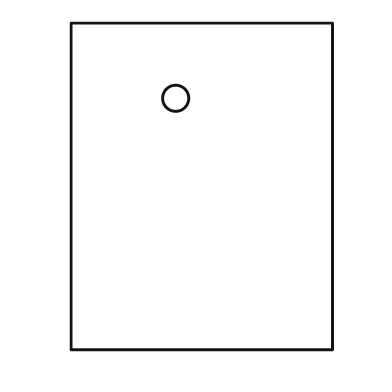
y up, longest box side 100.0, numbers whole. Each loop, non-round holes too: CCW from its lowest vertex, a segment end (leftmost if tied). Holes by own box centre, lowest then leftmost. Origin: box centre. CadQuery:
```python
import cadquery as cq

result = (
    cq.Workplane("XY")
    .moveTo(-40.0, -50.0)
    .lineTo(40.0, -50.0)
    .lineTo(40.0, 50.0)
    .lineTo(-40.0, 50.0)
    .close()
    .moveTo(-8.0, 27.0)
    .circle(4.0)
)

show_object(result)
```